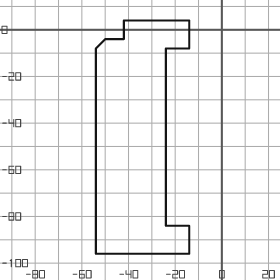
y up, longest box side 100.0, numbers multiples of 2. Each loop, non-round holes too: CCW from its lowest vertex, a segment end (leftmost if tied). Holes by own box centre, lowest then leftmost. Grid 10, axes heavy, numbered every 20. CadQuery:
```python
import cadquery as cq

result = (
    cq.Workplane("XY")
    .moveTo(-54.0, -96.0)
    .lineTo(-14.0, -96.0)
    .lineTo(-14.0, -84.0)
    .lineTo(-24.0, -84.0)
    .lineTo(-24.0, -8.0)
    .lineTo(-14.0, -8.0)
    .lineTo(-14.0, 4.0)
    .lineTo(-42.0, 4.0)
    .lineTo(-42.0, -4.0)
    .lineTo(-50.0, -4.0)
    .lineTo(-54.0, -8.0)
    .close()
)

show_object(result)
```